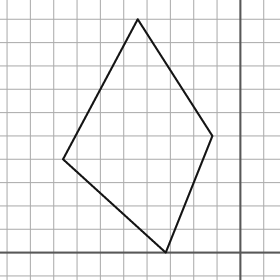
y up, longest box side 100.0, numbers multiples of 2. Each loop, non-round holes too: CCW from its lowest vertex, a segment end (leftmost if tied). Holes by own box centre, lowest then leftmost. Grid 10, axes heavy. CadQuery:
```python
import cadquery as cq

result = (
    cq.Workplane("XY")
    .moveTo(-32.0, 0.0)
    .lineTo(-12.0, 50.0)
    .lineTo(-44.0, 100.0)
    .lineTo(-76.0, 40.0)
    .close()
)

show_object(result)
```